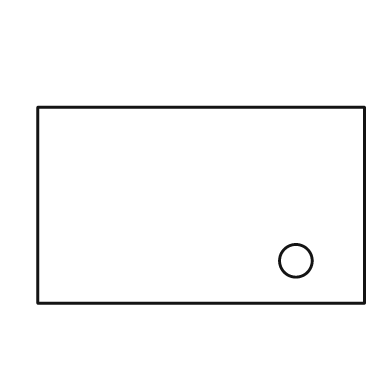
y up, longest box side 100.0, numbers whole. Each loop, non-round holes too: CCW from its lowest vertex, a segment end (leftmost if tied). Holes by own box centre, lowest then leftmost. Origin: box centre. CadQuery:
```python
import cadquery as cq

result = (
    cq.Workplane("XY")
    .moveTo(-50.0, -30.0)
    .lineTo(50.0, -30.0)
    .lineTo(50.0, 30.0)
    .lineTo(-50.0, 30.0)
    .close()
    .moveTo(29.0, -17.0)
    .circle(5.0)
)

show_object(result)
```